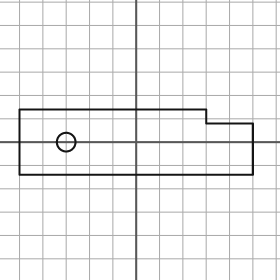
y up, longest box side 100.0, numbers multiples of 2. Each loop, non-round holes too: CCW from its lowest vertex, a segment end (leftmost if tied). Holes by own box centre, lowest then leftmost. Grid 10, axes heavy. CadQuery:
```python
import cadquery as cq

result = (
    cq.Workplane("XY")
    .moveTo(-50.0, -14.0)
    .lineTo(50.0, -14.0)
    .lineTo(50.0, 8.0)
    .lineTo(30.0, 8.0)
    .lineTo(30.0, 14.0)
    .lineTo(-50.0, 14.0)
    .close()
    .moveTo(-30.0, 0.0)
    .circle(4.0)
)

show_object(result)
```